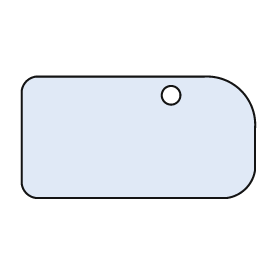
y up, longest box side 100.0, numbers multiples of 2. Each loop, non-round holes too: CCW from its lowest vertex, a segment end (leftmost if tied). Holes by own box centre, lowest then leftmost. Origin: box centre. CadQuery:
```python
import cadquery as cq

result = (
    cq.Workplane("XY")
    .moveTo(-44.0, -26.0)
    .lineTo(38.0, -26.0)
    .threePointArc((46.0, -22.0), (50.0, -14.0))
    .lineTo(50.0, 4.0)
    .threePointArc((44.0, 20.0), (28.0, 26.0))
    .lineTo(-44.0, 26.0)
    .threePointArc((-48.0, 24.0), (-50.0, 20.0))
    .lineTo(-50.0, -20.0)
    .threePointArc((-48.0, -24.0), (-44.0, -26.0))
    .close()
    .moveTo(14.0, 18.0)
    .circle(4.0)
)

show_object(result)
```